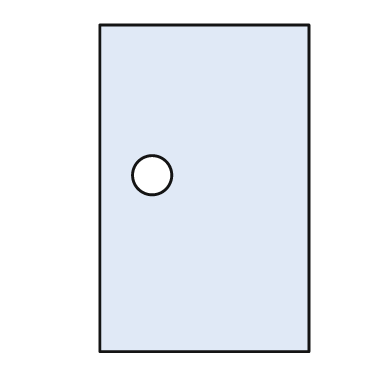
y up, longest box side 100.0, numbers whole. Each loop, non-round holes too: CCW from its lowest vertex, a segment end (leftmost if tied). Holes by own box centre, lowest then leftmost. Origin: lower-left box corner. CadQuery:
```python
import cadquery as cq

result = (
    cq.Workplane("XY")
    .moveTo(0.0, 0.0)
    .lineTo(64.0, 0.0)
    .lineTo(64.0, 100.0)
    .lineTo(0.0, 100.0)
    .close()
    .moveTo(16.0, 54.0)
    .circle(6.0)
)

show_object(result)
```